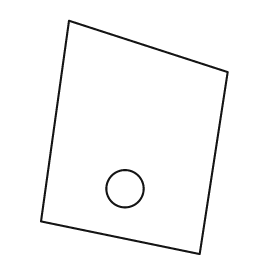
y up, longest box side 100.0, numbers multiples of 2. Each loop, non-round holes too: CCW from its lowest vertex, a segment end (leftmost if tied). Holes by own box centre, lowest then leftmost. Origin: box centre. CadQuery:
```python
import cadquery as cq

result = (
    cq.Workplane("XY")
    .moveTo(28.0, -50.0)
    .lineTo(40.0, 28.0)
    .lineTo(-28.0, 50.0)
    .lineTo(-40.0, -36.0)
    .close()
    .moveTo(-4.0, -22.0)
    .circle(8.0)
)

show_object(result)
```